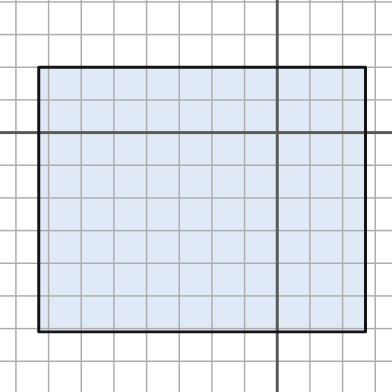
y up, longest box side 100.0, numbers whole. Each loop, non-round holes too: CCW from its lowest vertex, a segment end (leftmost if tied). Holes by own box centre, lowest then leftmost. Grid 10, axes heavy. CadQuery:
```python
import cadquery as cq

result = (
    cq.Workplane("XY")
    .moveTo(-73.0, -61.0)
    .lineTo(27.0, -61.0)
    .lineTo(27.0, 20.0)
    .lineTo(-73.0, 20.0)
    .close()
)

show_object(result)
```